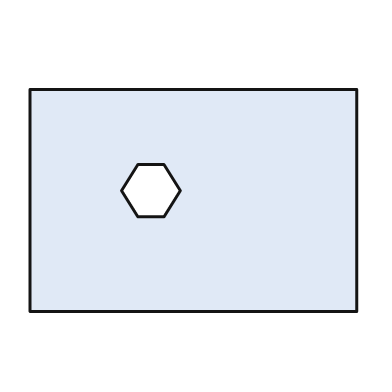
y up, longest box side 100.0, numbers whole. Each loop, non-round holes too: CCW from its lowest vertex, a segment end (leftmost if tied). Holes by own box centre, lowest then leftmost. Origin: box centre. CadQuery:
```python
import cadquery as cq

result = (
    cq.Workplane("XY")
    .moveTo(-50.0, -34.0)
    .lineTo(50.0, -34.0)
    .lineTo(50.0, 34.0)
    .lineTo(-50.0, 34.0)
    .close()
    .moveTo(-17.0, -5.0)
    .lineTo(-9.0, -5.0)
    .lineTo(-4.0, 3.0)
    .lineTo(-9.0, 11.0)
    .lineTo(-17.0, 11.0)
    .lineTo(-22.0, 3.0)
    .close()
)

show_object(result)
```